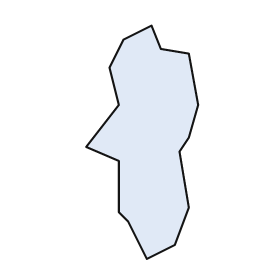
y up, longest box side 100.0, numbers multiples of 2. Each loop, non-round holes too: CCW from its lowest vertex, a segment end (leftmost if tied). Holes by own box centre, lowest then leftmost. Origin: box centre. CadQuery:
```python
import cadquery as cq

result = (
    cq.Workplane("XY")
    .moveTo(2.0, -50.0)
    .lineTo(14.0, -44.0)
    .lineTo(20.0, -28.0)
    .lineTo(16.0, -4.0)
    .lineTo(20.0, 2.0)
    .lineTo(24.0, 16.0)
    .lineTo(20.0, 38.0)
    .lineTo(8.0, 40.0)
    .lineTo(4.0, 50.0)
    .lineTo(-8.0, 44.0)
    .lineTo(-14.0, 32.0)
    .lineTo(-10.0, 16.0)
    .lineTo(-24.0, -2.0)
    .lineTo(-10.0, -8.0)
    .lineTo(-10.0, -30.0)
    .lineTo(-6.0, -34.0)
    .close()
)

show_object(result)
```